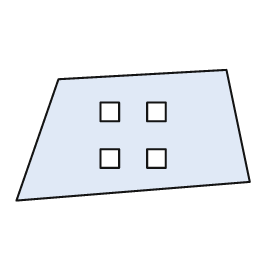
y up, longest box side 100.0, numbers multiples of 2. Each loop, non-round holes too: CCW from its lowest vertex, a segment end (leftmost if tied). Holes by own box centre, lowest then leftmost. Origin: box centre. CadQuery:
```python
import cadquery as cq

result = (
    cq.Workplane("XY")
    .moveTo(-50.0, -28.0)
    .lineTo(50.0, -20.0)
    .lineTo(40.0, 28.0)
    .lineTo(-32.0, 24.0)
    .close()
    .moveTo(-14.0, -14.0)
    .lineTo(-6.0, -14.0)
    .lineTo(-6.0, -6.0)
    .lineTo(-14.0, -6.0)
    .close()
    .moveTo(6.0, -14.0)
    .lineTo(14.0, -14.0)
    .lineTo(14.0, -6.0)
    .lineTo(6.0, -6.0)
    .close()
    .moveTo(-14.0, 6.0)
    .lineTo(-6.0, 6.0)
    .lineTo(-6.0, 14.0)
    .lineTo(-14.0, 14.0)
    .close()
    .moveTo(6.0, 6.0)
    .lineTo(14.0, 6.0)
    .lineTo(14.0, 14.0)
    .lineTo(6.0, 14.0)
    .close()
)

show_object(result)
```